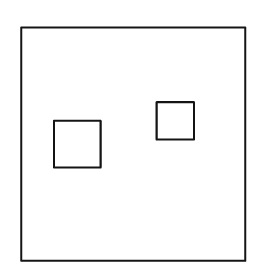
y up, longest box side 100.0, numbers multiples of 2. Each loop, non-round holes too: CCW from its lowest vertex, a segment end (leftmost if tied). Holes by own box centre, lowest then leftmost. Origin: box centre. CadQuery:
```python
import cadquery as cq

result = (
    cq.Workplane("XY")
    .moveTo(-48.0, -50.0)
    .lineTo(48.0, -50.0)
    .lineTo(48.0, 50.0)
    .lineTo(-48.0, 50.0)
    .close()
    .moveTo(-34.0, -10.0)
    .lineTo(-14.0, -10.0)
    .lineTo(-14.0, 10.0)
    .lineTo(-34.0, 10.0)
    .close()
    .moveTo(10.0, 2.0)
    .lineTo(26.0, 2.0)
    .lineTo(26.0, 18.0)
    .lineTo(10.0, 18.0)
    .close()
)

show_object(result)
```